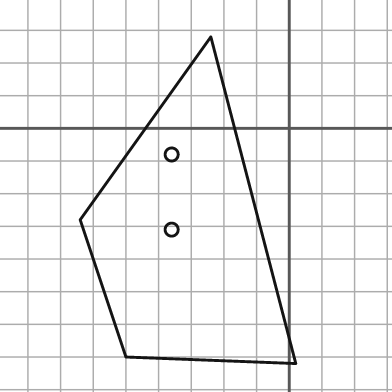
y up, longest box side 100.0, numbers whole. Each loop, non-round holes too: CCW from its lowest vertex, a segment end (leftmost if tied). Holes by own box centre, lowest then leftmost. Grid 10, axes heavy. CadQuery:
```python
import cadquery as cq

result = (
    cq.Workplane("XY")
    .moveTo(2.0, -72.0)
    .lineTo(-24.0, 28.0)
    .lineTo(-64.0, -28.0)
    .lineTo(-50.0, -70.0)
    .close()
    .moveTo(-36.0, -31.0)
    .circle(2.0)
    .moveTo(-36.0, -8.0)
    .circle(2.0)
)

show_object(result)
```